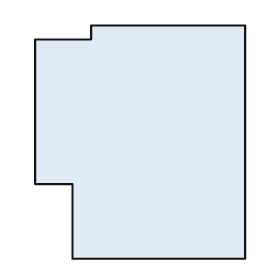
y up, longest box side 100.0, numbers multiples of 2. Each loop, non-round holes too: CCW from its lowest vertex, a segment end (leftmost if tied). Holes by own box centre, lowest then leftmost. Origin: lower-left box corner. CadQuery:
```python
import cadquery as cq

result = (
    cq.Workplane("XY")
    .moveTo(16.0, 0.0)
    .lineTo(90.0, 0.0)
    .lineTo(90.0, 100.0)
    .lineTo(24.0, 100.0)
    .lineTo(24.0, 94.0)
    .lineTo(0.0, 94.0)
    .lineTo(0.0, 32.0)
    .lineTo(16.0, 32.0)
    .close()
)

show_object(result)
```